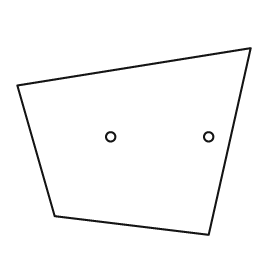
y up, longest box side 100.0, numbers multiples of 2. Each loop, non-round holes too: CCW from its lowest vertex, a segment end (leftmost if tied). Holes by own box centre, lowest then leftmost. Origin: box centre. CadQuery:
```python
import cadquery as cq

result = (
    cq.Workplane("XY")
    .moveTo(32.0, -40.0)
    .lineTo(50.0, 40.0)
    .lineTo(-50.0, 24.0)
    .lineTo(-34.0, -32.0)
    .close()
    .moveTo(-10.0, 2.0)
    .circle(2.0)
    .moveTo(32.0, 2.0)
    .circle(2.0)
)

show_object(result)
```